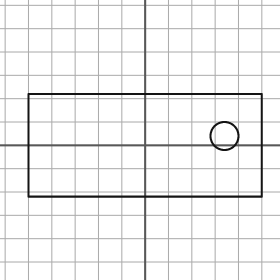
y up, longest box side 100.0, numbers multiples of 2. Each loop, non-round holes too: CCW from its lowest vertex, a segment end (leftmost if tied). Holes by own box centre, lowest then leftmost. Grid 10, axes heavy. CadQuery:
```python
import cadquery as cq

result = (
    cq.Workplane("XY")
    .moveTo(-50.0, -22.0)
    .lineTo(50.0, -22.0)
    .lineTo(50.0, 22.0)
    .lineTo(-50.0, 22.0)
    .close()
    .moveTo(34.0, 4.0)
    .circle(6.0)
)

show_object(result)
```